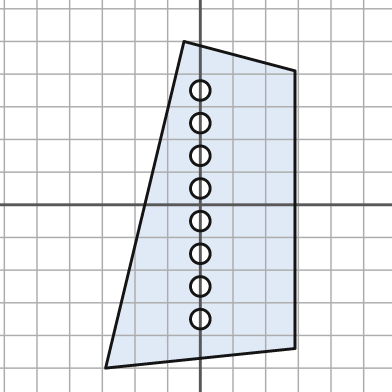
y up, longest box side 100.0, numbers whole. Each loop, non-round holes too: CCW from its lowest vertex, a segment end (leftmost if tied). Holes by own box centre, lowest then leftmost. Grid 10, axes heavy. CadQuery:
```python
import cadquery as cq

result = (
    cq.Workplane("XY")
    .moveTo(-29.0, -50.0)
    .lineTo(29.0, -44.0)
    .lineTo(29.0, 41.0)
    .lineTo(-5.0, 50.0)
    .close()
    .moveTo(0.0, -35.0)
    .circle(3.0)
    .moveTo(0.0, -25.0)
    .circle(3.0)
    .moveTo(0.0, -15.0)
    .circle(3.0)
    .moveTo(0.0, -5.0)
    .circle(3.0)
    .moveTo(0.0, 5.0)
    .circle(3.0)
    .moveTo(0.0, 15.0)
    .circle(3.0)
    .moveTo(0.0, 25.0)
    .circle(3.0)
    .moveTo(0.0, 35.0)
    .circle(3.0)
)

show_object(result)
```